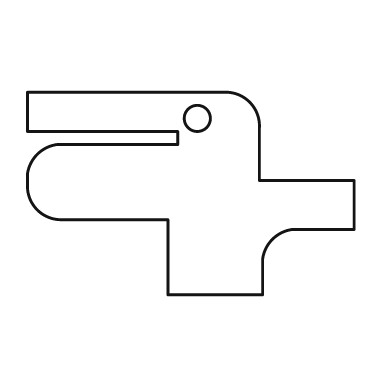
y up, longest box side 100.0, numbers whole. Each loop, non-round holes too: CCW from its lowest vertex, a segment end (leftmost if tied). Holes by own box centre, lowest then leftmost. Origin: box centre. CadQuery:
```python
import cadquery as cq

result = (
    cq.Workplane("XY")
    .moveTo(-7.0, -31.0)
    .lineTo(22.0, -31.0)
    .lineTo(22.0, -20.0)
    .threePointArc((25.0, -14.0), (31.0, -11.0))
    .lineTo(50.0, -11.0)
    .lineTo(50.0, 4.0)
    .lineTo(21.0, 4.0)
    .lineTo(21.0, 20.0)
    .threePointArc((18.0, 28.0), (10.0, 31.0))
    .lineTo(-50.0, 31.0)
    .lineTo(-50.0, 19.0)
    .lineTo(-4.0, 19.0)
    .lineTo(-4.0, 15.0)
    .lineTo(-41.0, 15.0)
    .threePointArc((-47.0, 12.0), (-50.0, 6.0))
    .lineTo(-50.0, 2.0)
    .threePointArc((-47.0, -5.0), (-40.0, -8.0))
    .lineTo(-7.0, -8.0)
    .close()
    .moveTo(2.0, 23.0)
    .circle(4.0)
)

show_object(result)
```